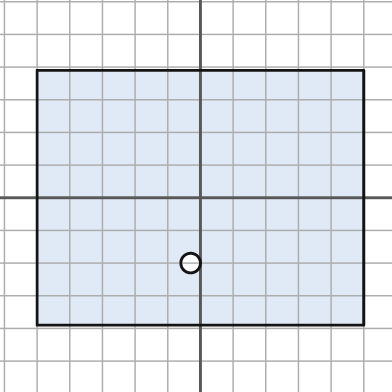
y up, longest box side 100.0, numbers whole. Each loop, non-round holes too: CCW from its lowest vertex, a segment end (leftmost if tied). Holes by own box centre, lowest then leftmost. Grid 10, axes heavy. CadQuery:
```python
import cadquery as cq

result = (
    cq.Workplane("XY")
    .moveTo(-50.0, -39.0)
    .lineTo(50.0, -39.0)
    .lineTo(50.0, 39.0)
    .lineTo(-50.0, 39.0)
    .close()
    .moveTo(-3.0, -20.0)
    .circle(3.0)
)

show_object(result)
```